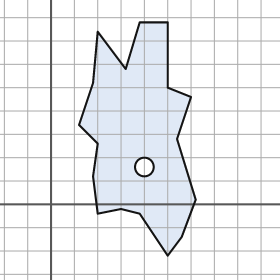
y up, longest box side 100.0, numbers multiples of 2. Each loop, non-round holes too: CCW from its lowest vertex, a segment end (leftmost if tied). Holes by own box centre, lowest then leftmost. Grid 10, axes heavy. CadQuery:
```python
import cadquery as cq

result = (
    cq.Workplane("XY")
    .moveTo(50.0, -22.0)
    .lineTo(56.0, -14.0)
    .lineTo(62.0, 2.0)
    .lineTo(54.0, 28.0)
    .lineTo(60.0, 46.0)
    .lineTo(50.0, 50.0)
    .lineTo(50.0, 78.0)
    .lineTo(38.0, 78.0)
    .lineTo(32.0, 58.0)
    .lineTo(20.0, 74.0)
    .lineTo(18.0, 52.0)
    .lineTo(12.0, 34.0)
    .lineTo(20.0, 26.0)
    .lineTo(18.0, 12.0)
    .lineTo(20.0, -4.0)
    .lineTo(30.0, -2.0)
    .lineTo(38.0, -4.0)
    .close()
    .moveTo(40.0, 16.0)
    .circle(4.0)
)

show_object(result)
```